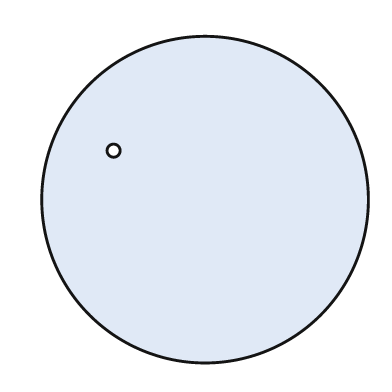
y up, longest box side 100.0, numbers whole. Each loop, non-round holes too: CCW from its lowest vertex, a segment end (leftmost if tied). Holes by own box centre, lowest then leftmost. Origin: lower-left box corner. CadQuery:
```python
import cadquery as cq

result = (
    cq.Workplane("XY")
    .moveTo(50.0, 50.0)
    .circle(50.0)
    .moveTo(22.0, 65.0)
    .circle(2.0)
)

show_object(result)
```